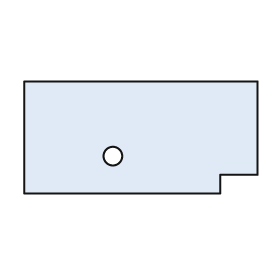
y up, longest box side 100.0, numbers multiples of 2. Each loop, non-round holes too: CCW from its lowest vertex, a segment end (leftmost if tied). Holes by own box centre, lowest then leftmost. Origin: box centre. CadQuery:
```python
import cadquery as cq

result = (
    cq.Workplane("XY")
    .moveTo(-50.0, -24.0)
    .lineTo(34.0, -24.0)
    .lineTo(34.0, -16.0)
    .lineTo(50.0, -16.0)
    .lineTo(50.0, 24.0)
    .lineTo(-50.0, 24.0)
    .close()
    .moveTo(-12.0, -8.0)
    .circle(4.0)
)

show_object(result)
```